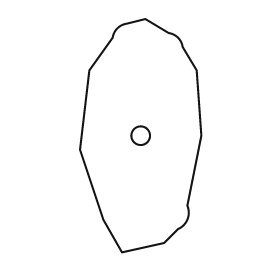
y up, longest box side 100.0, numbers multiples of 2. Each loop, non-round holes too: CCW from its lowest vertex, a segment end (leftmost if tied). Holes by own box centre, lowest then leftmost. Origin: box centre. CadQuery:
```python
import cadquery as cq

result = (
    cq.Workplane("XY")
    .moveTo(-8.0, -50.0)
    .lineTo(10.0, -46.0)
    .lineTo(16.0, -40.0)
    .threePointArc((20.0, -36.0), (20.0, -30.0))
    .lineTo(26.0, 0.0)
    .lineTo(24.0, 28.0)
    .lineTo(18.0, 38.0)
    .threePointArc((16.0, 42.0), (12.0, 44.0))
    .lineTo(2.0, 50.0)
    .lineTo(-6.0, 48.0)
    .threePointArc((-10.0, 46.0), (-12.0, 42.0))
    .lineTo(-22.0, 28.0)
    .lineTo(-26.0, -6.0)
    .lineTo(-16.0, -36.0)
    .close()
    .moveTo(0.0, 0.0)
    .circle(4.0)
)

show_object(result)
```